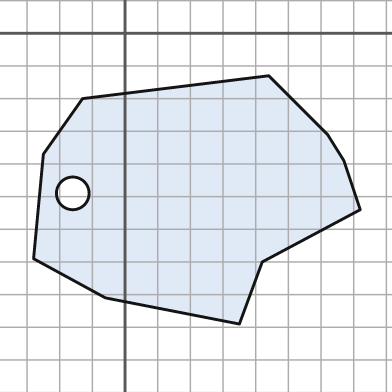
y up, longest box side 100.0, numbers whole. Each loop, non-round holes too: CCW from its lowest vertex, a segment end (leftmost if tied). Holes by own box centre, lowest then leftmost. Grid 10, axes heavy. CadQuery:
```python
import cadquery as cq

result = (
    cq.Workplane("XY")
    .moveTo(35.0, -89.0)
    .lineTo(42.0, -70.0)
    .lineTo(72.0, -54.0)
    .lineTo(67.0, -39.0)
    .lineTo(62.0, -31.0)
    .lineTo(44.0, -13.0)
    .lineTo(-13.0, -20.0)
    .lineTo(-25.0, -37.0)
    .lineTo(-28.0, -69.0)
    .lineTo(-6.0, -81.0)
    .close()
    .moveTo(-16.0, -49.0)
    .circle(5.0)
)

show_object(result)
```